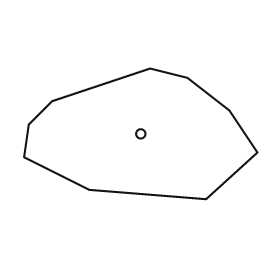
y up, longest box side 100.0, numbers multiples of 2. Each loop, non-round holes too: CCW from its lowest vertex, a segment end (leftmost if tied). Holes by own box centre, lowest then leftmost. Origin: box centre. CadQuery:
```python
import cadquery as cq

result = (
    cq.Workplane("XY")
    .moveTo(28.0, -28.0)
    .lineTo(50.0, -8.0)
    .lineTo(38.0, 10.0)
    .lineTo(20.0, 24.0)
    .lineTo(4.0, 28.0)
    .lineTo(-38.0, 14.0)
    .lineTo(-48.0, 4.0)
    .lineTo(-50.0, -10.0)
    .lineTo(-22.0, -24.0)
    .close()
    .moveTo(0.0, 0.0)
    .circle(2.0)
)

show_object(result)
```